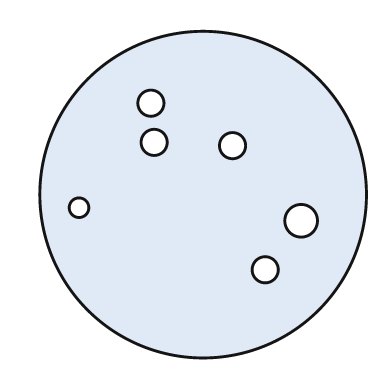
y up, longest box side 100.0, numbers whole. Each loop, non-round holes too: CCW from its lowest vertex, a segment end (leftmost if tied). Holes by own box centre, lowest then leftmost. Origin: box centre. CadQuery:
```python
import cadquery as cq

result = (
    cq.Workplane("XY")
    .moveTo(0.0, 0.0)
    .circle(50.0)
    .moveTo(19.0, -23.0)
    .circle(4.0)
    .moveTo(30.0, -8.0)
    .circle(5.0)
    .moveTo(-38.0, -4.0)
    .circle(3.0)
    .moveTo(9.0, 15.0)
    .circle(4.0)
    .moveTo(-15.0, 16.0)
    .circle(4.0)
    .moveTo(-16.0, 28.0)
    .circle(4.0)
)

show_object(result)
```